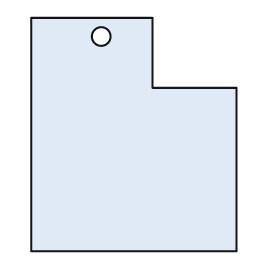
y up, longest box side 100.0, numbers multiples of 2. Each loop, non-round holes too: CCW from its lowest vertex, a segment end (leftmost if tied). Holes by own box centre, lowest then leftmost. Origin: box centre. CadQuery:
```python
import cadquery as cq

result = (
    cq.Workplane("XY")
    .moveTo(-44.0, -50.0)
    .lineTo(44.0, -50.0)
    .lineTo(44.0, 20.0)
    .lineTo(8.0, 20.0)
    .lineTo(8.0, 50.0)
    .lineTo(-44.0, 50.0)
    .close()
    .moveTo(-14.0, 42.0)
    .circle(4.0)
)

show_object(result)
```